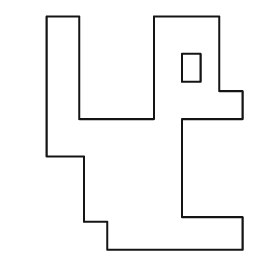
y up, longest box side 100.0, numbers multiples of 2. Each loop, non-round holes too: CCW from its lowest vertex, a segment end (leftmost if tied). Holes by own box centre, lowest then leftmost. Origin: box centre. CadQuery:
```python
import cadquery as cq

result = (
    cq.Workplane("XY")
    .moveTo(-16.0, -50.0)
    .lineTo(42.0, -50.0)
    .lineTo(42.0, -36.0)
    .lineTo(16.0, -36.0)
    .lineTo(16.0, 6.0)
    .lineTo(42.0, 6.0)
    .lineTo(42.0, 18.0)
    .lineTo(32.0, 18.0)
    .lineTo(32.0, 50.0)
    .lineTo(4.0, 50.0)
    .lineTo(4.0, 6.0)
    .lineTo(-28.0, 6.0)
    .lineTo(-28.0, 50.0)
    .lineTo(-42.0, 50.0)
    .lineTo(-42.0, -10.0)
    .lineTo(-26.0, -10.0)
    .lineTo(-26.0, -38.0)
    .lineTo(-16.0, -38.0)
    .close()
    .moveTo(16.0, 22.0)
    .lineTo(24.0, 22.0)
    .lineTo(24.0, 34.0)
    .lineTo(16.0, 34.0)
    .close()
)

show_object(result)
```